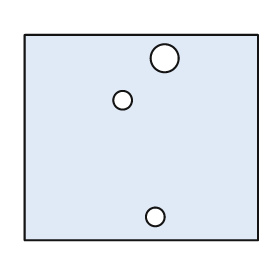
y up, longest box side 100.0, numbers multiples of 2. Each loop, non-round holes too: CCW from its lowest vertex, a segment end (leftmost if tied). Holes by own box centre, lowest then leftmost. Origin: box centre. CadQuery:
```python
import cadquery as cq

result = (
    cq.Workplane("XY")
    .moveTo(-50.0, -44.0)
    .lineTo(50.0, -44.0)
    .lineTo(50.0, 44.0)
    .lineTo(-50.0, 44.0)
    .close()
    .moveTo(6.0, -34.0)
    .circle(4.0)
    .moveTo(-8.0, 16.0)
    .circle(4.0)
    .moveTo(10.0, 34.0)
    .circle(6.0)
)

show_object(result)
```